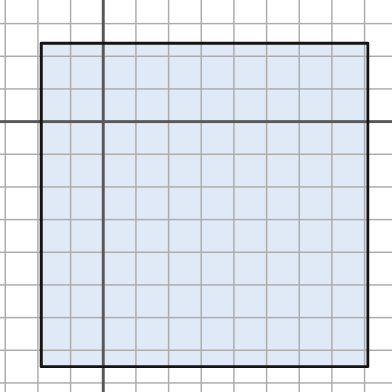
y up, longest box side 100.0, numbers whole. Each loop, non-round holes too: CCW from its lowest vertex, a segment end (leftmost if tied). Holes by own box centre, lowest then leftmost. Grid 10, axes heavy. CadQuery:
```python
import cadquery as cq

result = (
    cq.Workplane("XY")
    .moveTo(-19.0, -75.0)
    .lineTo(81.0, -75.0)
    .lineTo(81.0, 24.0)
    .lineTo(-19.0, 24.0)
    .close()
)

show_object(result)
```